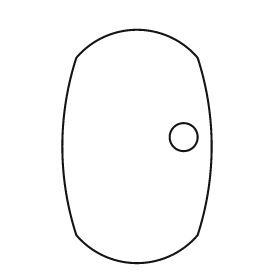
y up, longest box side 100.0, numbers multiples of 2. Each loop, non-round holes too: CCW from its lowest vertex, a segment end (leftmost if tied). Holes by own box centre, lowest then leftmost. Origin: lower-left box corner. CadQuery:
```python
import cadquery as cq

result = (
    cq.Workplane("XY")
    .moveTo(6.0, 12.0)
    .threePointArc((32.0, 0.0), (58.0, 12.0))
    .threePointArc((64.0, 50.0), (58.0, 88.0))
    .threePointArc((32.0, 100.0), (6.0, 88.0))
    .threePointArc((0.0, 50.0), (6.0, 12.0))
    .close()
    .moveTo(52.0, 54.0)
    .circle(6.0)
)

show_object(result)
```